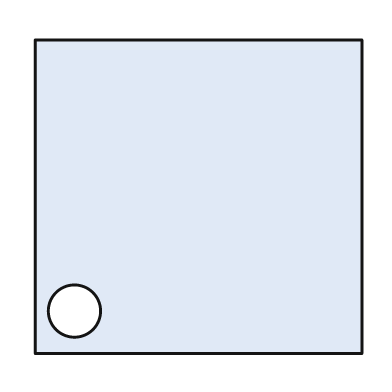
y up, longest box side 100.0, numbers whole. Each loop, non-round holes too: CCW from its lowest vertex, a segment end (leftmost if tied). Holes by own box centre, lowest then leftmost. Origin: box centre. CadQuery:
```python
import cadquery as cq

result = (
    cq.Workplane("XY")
    .moveTo(-50.0, -48.0)
    .lineTo(50.0, -48.0)
    .lineTo(50.0, 48.0)
    .lineTo(-50.0, 48.0)
    .close()
    .moveTo(-38.0, -35.0)
    .circle(8.0)
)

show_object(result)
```